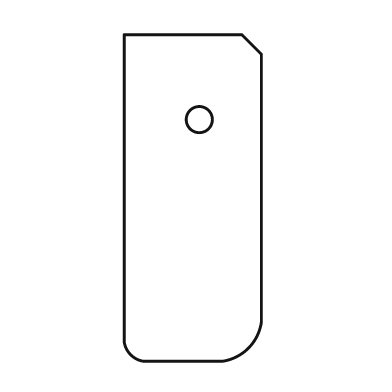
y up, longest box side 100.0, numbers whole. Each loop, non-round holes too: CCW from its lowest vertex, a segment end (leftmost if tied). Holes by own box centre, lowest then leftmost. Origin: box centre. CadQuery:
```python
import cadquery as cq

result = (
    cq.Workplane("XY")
    .moveTo(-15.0, -50.0)
    .lineTo(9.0, -50.0)
    .threePointArc((17.0, -46.0), (21.0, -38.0))
    .lineTo(21.0, 44.0)
    .lineTo(15.0, 50.0)
    .lineTo(-21.0, 50.0)
    .lineTo(-21.0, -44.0)
    .threePointArc((-19.0, -48.0), (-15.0, -50.0))
    .close()
    .moveTo(2.0, 24.0)
    .circle(4.0)
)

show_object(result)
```